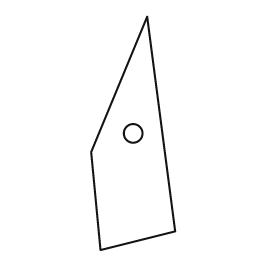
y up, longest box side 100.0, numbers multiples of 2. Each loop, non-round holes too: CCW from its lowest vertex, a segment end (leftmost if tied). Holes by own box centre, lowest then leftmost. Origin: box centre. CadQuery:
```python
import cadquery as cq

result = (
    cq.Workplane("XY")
    .moveTo(-14.0, -50.0)
    .lineTo(18.0, -42.0)
    .lineTo(6.0, 50.0)
    .lineTo(-18.0, -8.0)
    .close()
    .moveTo(0.0, 0.0)
    .circle(4.0)
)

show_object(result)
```